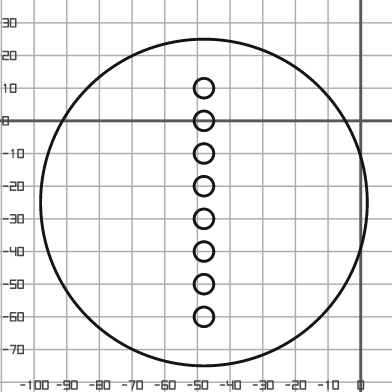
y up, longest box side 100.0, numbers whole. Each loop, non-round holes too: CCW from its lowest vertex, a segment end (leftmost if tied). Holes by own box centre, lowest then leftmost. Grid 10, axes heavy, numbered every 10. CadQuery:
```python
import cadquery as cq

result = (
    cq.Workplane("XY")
    .moveTo(-48.0, -25.0)
    .circle(50.0)
    .moveTo(-48.0, -60.0)
    .circle(3.0)
    .moveTo(-48.0, -50.0)
    .circle(3.0)
    .moveTo(-48.0, -40.0)
    .circle(3.0)
    .moveTo(-48.0, -30.0)
    .circle(3.0)
    .moveTo(-48.0, -20.0)
    .circle(3.0)
    .moveTo(-48.0, -10.0)
    .circle(3.0)
    .moveTo(-48.0, 0.0)
    .circle(3.0)
    .moveTo(-48.0, 10.0)
    .circle(3.0)
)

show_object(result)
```